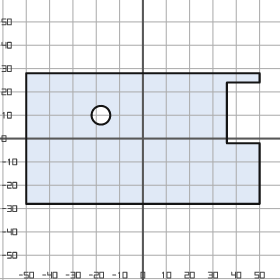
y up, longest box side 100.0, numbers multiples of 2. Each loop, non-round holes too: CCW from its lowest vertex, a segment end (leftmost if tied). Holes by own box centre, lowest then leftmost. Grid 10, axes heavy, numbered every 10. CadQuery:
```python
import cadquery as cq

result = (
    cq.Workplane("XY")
    .moveTo(-50.0, -28.0)
    .lineTo(50.0, -28.0)
    .lineTo(50.0, -2.0)
    .lineTo(36.0, -2.0)
    .lineTo(36.0, 24.0)
    .lineTo(50.0, 24.0)
    .lineTo(50.0, 28.0)
    .lineTo(-50.0, 28.0)
    .close()
    .moveTo(-18.0, 10.0)
    .circle(4.0)
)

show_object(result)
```